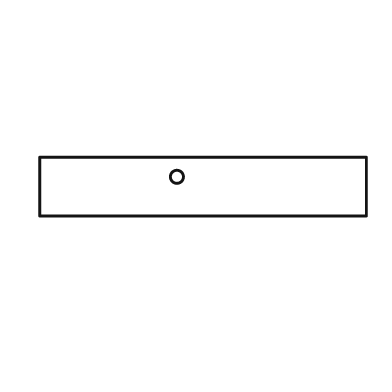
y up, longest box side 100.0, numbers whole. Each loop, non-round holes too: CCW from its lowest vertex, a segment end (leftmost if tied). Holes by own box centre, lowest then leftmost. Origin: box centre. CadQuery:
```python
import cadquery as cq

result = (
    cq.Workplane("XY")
    .moveTo(-50.0, -9.0)
    .lineTo(50.0, -9.0)
    .lineTo(50.0, 9.0)
    .lineTo(-50.0, 9.0)
    .close()
    .moveTo(-8.0, 3.0)
    .circle(2.0)
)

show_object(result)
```